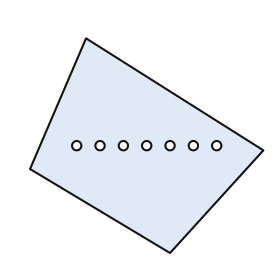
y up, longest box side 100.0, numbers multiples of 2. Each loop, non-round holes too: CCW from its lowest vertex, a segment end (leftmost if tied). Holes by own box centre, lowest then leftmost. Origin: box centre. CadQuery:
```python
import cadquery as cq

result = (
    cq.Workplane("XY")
    .moveTo(10.0, -46.0)
    .lineTo(50.0, -2.0)
    .lineTo(-26.0, 46.0)
    .lineTo(-50.0, -10.0)
    .close()
    .moveTo(-30.0, 0.0)
    .circle(2.0)
    .moveTo(-20.0, 0.0)
    .circle(2.0)
    .moveTo(-10.0, 0.0)
    .circle(2.0)
    .moveTo(0.0, 0.0)
    .circle(2.0)
    .moveTo(10.0, 0.0)
    .circle(2.0)
    .moveTo(20.0, 0.0)
    .circle(2.0)
    .moveTo(30.0, 0.0)
    .circle(2.0)
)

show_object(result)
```